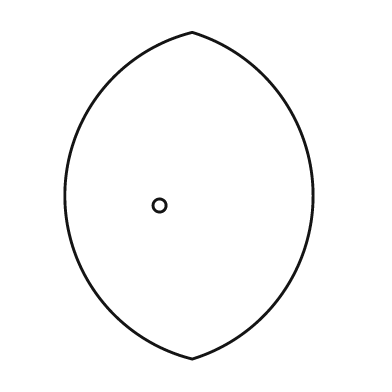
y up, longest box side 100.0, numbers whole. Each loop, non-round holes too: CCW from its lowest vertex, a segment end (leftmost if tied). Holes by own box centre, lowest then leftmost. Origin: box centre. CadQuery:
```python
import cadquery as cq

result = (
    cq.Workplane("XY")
    .moveTo(1.0, -50.0)
    .threePointArc((38.0, 0.0), (1.0, 50.0))
    .threePointArc((-38.0, 0.0), (1.0, -50.0))
    .close()
    .moveTo(-9.0, -3.0)
    .circle(2.0)
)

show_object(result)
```